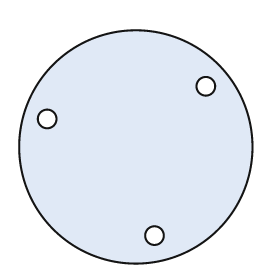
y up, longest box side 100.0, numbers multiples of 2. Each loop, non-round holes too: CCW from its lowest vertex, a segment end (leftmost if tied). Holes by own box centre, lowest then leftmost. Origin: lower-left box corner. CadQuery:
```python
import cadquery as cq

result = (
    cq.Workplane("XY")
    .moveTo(50.0, 50.0)
    .circle(50.0)
    .moveTo(58.0, 12.0)
    .circle(4.0)
    .moveTo(12.0, 62.0)
    .circle(4.0)
    .moveTo(80.0, 76.0)
    .circle(4.0)
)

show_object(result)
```